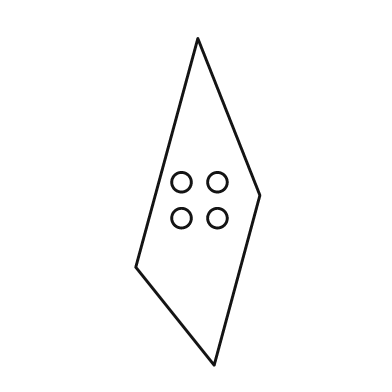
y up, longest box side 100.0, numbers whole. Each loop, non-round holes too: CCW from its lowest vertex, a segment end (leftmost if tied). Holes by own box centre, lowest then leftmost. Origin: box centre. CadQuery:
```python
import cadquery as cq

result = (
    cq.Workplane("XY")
    .moveTo(5.0, -50.0)
    .lineTo(19.0, 2.0)
    .lineTo(0.0, 50.0)
    .lineTo(-19.0, -20.0)
    .close()
    .moveTo(-5.0, -5.0)
    .circle(3.0)
    .moveTo(6.0, -5.0)
    .circle(3.0)
    .moveTo(-5.0, 6.0)
    .circle(3.0)
    .moveTo(6.0, 6.0)
    .circle(3.0)
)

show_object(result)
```